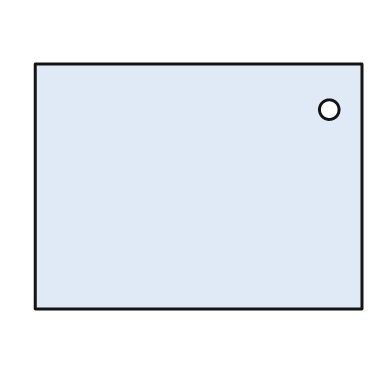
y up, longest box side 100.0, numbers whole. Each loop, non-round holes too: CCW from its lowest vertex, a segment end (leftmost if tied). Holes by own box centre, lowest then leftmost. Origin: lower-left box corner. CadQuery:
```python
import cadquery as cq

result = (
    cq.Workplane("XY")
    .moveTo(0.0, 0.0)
    .lineTo(100.0, 0.0)
    .lineTo(100.0, 75.0)
    .lineTo(0.0, 75.0)
    .close()
    .moveTo(90.0, 61.0)
    .circle(3.0)
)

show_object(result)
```